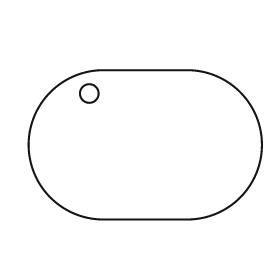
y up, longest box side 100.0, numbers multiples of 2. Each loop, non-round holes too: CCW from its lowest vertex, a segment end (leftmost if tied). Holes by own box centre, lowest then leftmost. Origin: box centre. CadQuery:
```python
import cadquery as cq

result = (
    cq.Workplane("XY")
    .moveTo(-18.0, -32.0)
    .lineTo(18.0, -32.0)
    .threePointArc((50.0, 0.0), (18.0, 32.0))
    .lineTo(-18.0, 32.0)
    .threePointArc((-50.0, 0.0), (-18.0, -32.0))
    .close()
    .moveTo(-24.0, 22.0)
    .circle(4.0)
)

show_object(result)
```